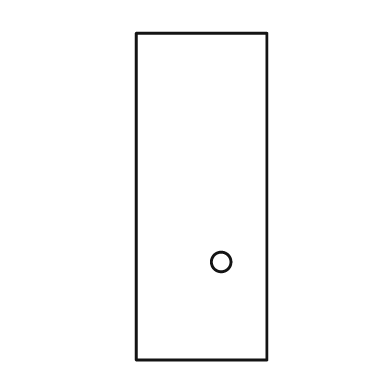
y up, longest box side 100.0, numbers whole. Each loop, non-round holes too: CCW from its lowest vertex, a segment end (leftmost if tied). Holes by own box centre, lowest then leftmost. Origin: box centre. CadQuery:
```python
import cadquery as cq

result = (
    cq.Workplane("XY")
    .moveTo(-20.0, -50.0)
    .lineTo(20.0, -50.0)
    .lineTo(20.0, 50.0)
    .lineTo(-20.0, 50.0)
    .close()
    .moveTo(6.0, -20.0)
    .circle(3.0)
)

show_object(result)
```